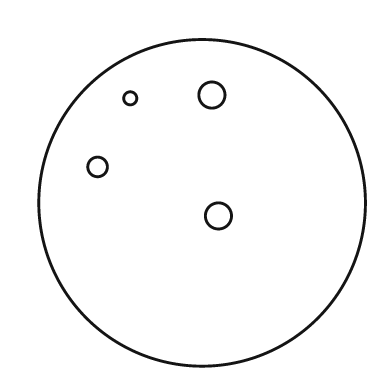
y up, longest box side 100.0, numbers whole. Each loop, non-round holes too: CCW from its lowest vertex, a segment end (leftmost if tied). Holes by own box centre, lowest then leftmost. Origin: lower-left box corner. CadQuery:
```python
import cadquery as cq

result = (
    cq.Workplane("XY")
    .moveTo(50.0, 50.0)
    .circle(50.0)
    .moveTo(55.0, 46.0)
    .circle(4.0)
    .moveTo(18.0, 61.0)
    .circle(3.0)
    .moveTo(28.0, 82.0)
    .circle(2.0)
    .moveTo(53.0, 83.0)
    .circle(4.0)
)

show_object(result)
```